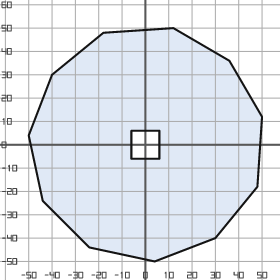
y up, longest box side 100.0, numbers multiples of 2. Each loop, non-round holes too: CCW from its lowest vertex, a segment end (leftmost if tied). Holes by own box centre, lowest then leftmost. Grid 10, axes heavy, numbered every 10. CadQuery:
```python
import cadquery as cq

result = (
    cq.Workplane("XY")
    .moveTo(4.0, -50.0)
    .lineTo(30.0, -40.0)
    .lineTo(48.0, -18.0)
    .lineTo(50.0, 12.0)
    .lineTo(36.0, 36.0)
    .lineTo(12.0, 50.0)
    .lineTo(-18.0, 48.0)
    .lineTo(-40.0, 30.0)
    .lineTo(-50.0, 4.0)
    .lineTo(-44.0, -24.0)
    .lineTo(-24.0, -44.0)
    .close()
    .moveTo(-6.0, -6.0)
    .lineTo(6.0, -6.0)
    .lineTo(6.0, 6.0)
    .lineTo(-6.0, 6.0)
    .close()
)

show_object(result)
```